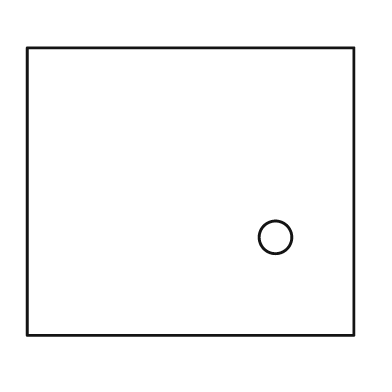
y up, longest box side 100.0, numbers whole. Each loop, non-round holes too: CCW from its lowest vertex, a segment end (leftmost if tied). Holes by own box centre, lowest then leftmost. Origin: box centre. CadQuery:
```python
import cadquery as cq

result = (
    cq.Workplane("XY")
    .moveTo(-50.0, -44.0)
    .lineTo(50.0, -44.0)
    .lineTo(50.0, 44.0)
    .lineTo(-50.0, 44.0)
    .close()
    .moveTo(26.0, -14.0)
    .circle(5.0)
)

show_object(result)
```